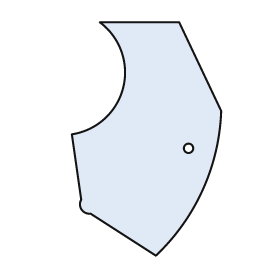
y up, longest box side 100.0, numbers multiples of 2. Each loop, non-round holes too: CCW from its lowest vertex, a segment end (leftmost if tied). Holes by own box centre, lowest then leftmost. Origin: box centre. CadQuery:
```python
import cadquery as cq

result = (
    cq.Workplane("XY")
    .moveTo(4.0, -50.0)
    .threePointArc((24.0, -22.0), (32.0, 12.0))
    .lineTo(14.0, 50.0)
    .lineTo(-20.0, 50.0)
    .threePointArc((-10.0, 22.0), (-32.0, 2.0))
    .lineTo(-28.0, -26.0)
    .threePointArc((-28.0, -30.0), (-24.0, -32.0))
    .close()
    .moveTo(18.0, -4.0)
    .circle(2.0)
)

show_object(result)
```